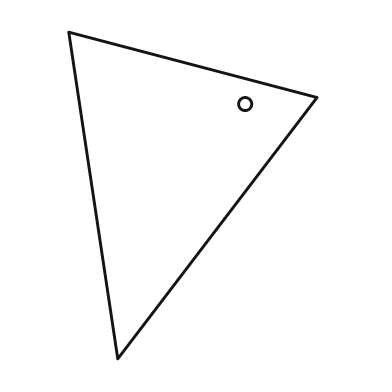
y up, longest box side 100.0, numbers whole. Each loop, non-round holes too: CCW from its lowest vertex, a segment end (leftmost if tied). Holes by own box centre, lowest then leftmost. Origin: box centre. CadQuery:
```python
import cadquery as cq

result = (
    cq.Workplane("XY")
    .moveTo(-23.0, -50.0)
    .lineTo(38.0, 30.0)
    .lineTo(-38.0, 50.0)
    .close()
    .moveTo(16.0, 28.0)
    .circle(2.0)
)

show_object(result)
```